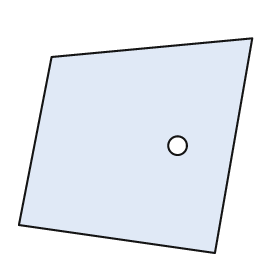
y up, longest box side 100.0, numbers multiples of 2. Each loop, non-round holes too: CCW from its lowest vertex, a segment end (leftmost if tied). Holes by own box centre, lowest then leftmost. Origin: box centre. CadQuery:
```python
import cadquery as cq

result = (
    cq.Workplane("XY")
    .moveTo(34.0, -46.0)
    .lineTo(50.0, 46.0)
    .lineTo(-36.0, 38.0)
    .lineTo(-50.0, -34.0)
    .close()
    .moveTo(18.0, 0.0)
    .circle(4.0)
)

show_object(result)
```